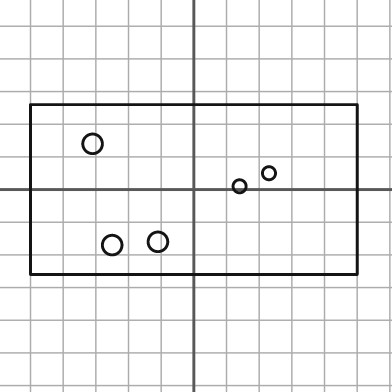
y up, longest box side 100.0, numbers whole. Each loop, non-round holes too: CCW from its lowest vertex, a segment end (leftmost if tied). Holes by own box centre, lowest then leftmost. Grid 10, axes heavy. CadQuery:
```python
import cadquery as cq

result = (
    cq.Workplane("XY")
    .moveTo(-50.0, -26.0)
    .lineTo(50.0, -26.0)
    .lineTo(50.0, 26.0)
    .lineTo(-50.0, 26.0)
    .close()
    .moveTo(-25.0, -17.0)
    .circle(3.0)
    .moveTo(-11.0, -16.0)
    .circle(3.0)
    .moveTo(14.0, 1.0)
    .circle(2.0)
    .moveTo(23.0, 5.0)
    .circle(2.0)
    .moveTo(-31.0, 14.0)
    .circle(3.0)
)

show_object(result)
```